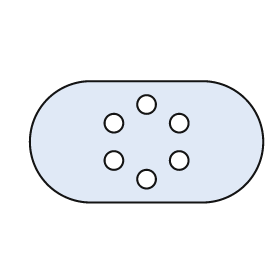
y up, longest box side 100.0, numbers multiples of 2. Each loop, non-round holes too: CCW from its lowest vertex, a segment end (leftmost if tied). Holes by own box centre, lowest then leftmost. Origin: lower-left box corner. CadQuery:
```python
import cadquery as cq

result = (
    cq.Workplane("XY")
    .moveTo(26.0, 0.0)
    .lineTo(74.0, 0.0)
    .threePointArc((100.0, 26.0), (74.0, 52.0))
    .lineTo(26.0, 52.0)
    .threePointArc((0.0, 26.0), (26.0, 0.0))
    .close()
    .moveTo(50.0, 10.0)
    .circle(4.0)
    .moveTo(36.0, 18.0)
    .circle(4.0)
    .moveTo(64.0, 18.0)
    .circle(4.0)
    .moveTo(36.0, 34.0)
    .circle(4.0)
    .moveTo(64.0, 34.0)
    .circle(4.0)
    .moveTo(50.0, 42.0)
    .circle(4.0)
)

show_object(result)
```